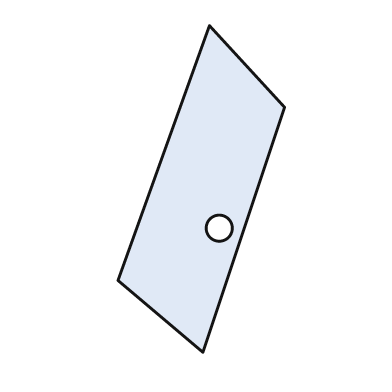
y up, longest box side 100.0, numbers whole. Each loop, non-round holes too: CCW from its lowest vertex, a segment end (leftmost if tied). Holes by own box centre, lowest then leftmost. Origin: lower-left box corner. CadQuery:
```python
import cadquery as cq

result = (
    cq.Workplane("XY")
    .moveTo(26.0, 0.0)
    .lineTo(51.0, 75.0)
    .lineTo(28.0, 100.0)
    .lineTo(0.0, 22.0)
    .close()
    .moveTo(31.0, 38.0)
    .circle(4.0)
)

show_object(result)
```